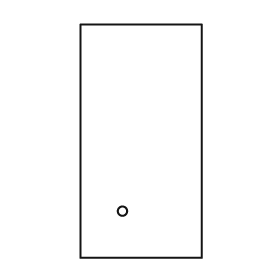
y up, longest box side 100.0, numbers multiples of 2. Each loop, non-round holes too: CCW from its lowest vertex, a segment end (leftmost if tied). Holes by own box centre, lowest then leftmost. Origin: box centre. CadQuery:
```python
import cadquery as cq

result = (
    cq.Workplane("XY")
    .moveTo(-26.0, -50.0)
    .lineTo(26.0, -50.0)
    .lineTo(26.0, 50.0)
    .lineTo(-26.0, 50.0)
    .close()
    .moveTo(-8.0, -30.0)
    .circle(2.0)
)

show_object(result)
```